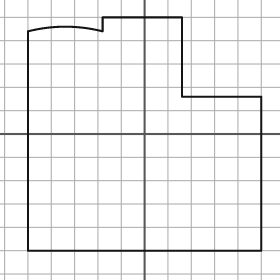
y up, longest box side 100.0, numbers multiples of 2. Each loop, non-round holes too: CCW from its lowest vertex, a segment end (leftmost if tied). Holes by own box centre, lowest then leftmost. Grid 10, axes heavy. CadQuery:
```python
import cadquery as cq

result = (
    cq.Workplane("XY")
    .moveTo(-50.0, -50.0)
    .lineTo(50.0, -50.0)
    .lineTo(50.0, 16.0)
    .lineTo(16.0, 16.0)
    .lineTo(16.0, 50.0)
    .lineTo(-18.0, 50.0)
    .lineTo(-18.0, 44.0)
    .threePointArc((-34.0, 46.0), (-50.0, 44.0))
    .close()
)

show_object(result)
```